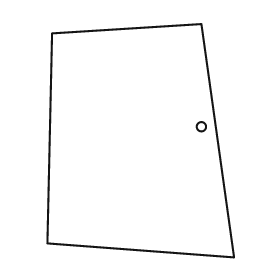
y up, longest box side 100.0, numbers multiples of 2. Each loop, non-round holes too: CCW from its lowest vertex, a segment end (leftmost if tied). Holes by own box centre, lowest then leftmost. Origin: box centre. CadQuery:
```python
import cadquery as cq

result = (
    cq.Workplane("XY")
    .moveTo(40.0, -50.0)
    .lineTo(26.0, 50.0)
    .lineTo(-38.0, 46.0)
    .lineTo(-40.0, -44.0)
    .close()
    .moveTo(26.0, 6.0)
    .circle(2.0)
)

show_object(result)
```